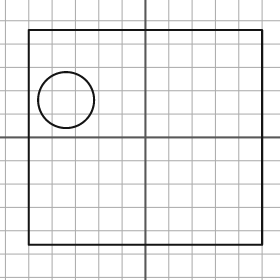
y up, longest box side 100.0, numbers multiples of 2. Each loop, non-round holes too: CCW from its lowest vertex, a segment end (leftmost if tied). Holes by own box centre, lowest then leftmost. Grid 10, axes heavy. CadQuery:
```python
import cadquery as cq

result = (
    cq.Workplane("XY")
    .moveTo(-50.0, -46.0)
    .lineTo(50.0, -46.0)
    .lineTo(50.0, 46.0)
    .lineTo(-50.0, 46.0)
    .close()
    .moveTo(-34.0, 16.0)
    .circle(12.0)
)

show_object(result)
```